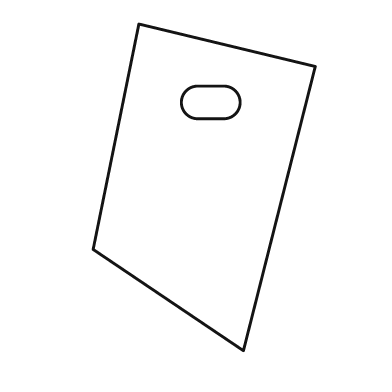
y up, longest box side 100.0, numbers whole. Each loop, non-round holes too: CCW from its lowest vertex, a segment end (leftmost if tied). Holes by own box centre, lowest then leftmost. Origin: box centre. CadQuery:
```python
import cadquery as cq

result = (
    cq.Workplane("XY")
    .moveTo(12.0, -50.0)
    .lineTo(34.0, 37.0)
    .lineTo(-20.0, 50.0)
    .lineTo(-34.0, -19.0)
    .close()
    .moveTo(-2.0, 21.0)
    .lineTo(6.0, 21.0)
    .threePointArc((11.0, 26.0), (6.0, 31.0))
    .lineTo(-2.0, 31.0)
    .threePointArc((-7.0, 26.0), (-2.0, 21.0))
    .close()
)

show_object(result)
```